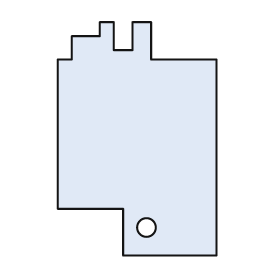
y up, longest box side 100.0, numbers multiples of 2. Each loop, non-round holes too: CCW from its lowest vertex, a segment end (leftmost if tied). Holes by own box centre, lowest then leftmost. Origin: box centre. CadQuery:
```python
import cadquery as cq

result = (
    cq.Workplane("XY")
    .moveTo(-6.0, -50.0)
    .lineTo(34.0, -50.0)
    .lineTo(34.0, 34.0)
    .lineTo(6.0, 34.0)
    .lineTo(6.0, 50.0)
    .lineTo(-2.0, 50.0)
    .lineTo(-2.0, 38.0)
    .lineTo(-10.0, 38.0)
    .lineTo(-10.0, 50.0)
    .lineTo(-16.0, 50.0)
    .lineTo(-16.0, 44.0)
    .lineTo(-28.0, 44.0)
    .lineTo(-28.0, 34.0)
    .lineTo(-34.0, 34.0)
    .lineTo(-34.0, -30.0)
    .lineTo(-6.0, -30.0)
    .close()
    .moveTo(4.0, -38.0)
    .circle(4.0)
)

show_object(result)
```